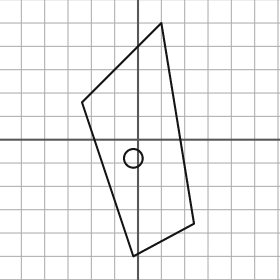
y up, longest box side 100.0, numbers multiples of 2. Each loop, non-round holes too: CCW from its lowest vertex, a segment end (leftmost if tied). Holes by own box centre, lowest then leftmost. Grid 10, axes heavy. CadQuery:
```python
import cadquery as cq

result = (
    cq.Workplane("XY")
    .moveTo(-2.0, -50.0)
    .lineTo(24.0, -36.0)
    .lineTo(10.0, 50.0)
    .lineTo(-24.0, 16.0)
    .close()
    .moveTo(-2.0, -8.0)
    .circle(4.0)
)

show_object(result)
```